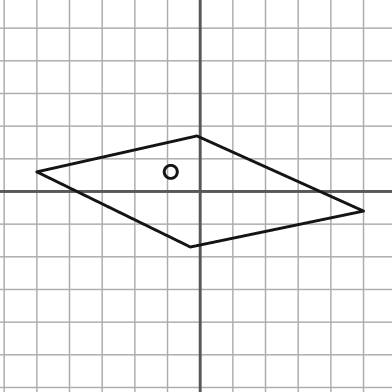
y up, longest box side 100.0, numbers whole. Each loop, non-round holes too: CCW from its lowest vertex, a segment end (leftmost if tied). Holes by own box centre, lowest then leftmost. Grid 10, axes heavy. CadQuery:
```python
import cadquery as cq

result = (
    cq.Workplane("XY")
    .moveTo(-3.0, -17.0)
    .lineTo(50.0, -6.0)
    .lineTo(-1.0, 17.0)
    .lineTo(-50.0, 6.0)
    .close()
    .moveTo(-9.0, 6.0)
    .circle(2.0)
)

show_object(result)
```